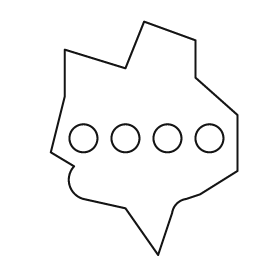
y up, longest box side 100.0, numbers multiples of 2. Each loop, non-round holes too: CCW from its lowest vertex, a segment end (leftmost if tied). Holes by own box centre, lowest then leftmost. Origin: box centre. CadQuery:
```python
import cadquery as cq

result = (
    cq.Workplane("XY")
    .moveTo(6.0, -50.0)
    .lineTo(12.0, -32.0)
    .threePointArc((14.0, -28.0), (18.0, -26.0))
    .lineTo(24.0, -24.0)
    .lineTo(40.0, -14.0)
    .lineTo(40.0, 10.0)
    .lineTo(22.0, 26.0)
    .lineTo(22.0, 42.0)
    .lineTo(0.0, 50.0)
    .lineTo(-8.0, 30.0)
    .lineTo(-34.0, 38.0)
    .lineTo(-34.0, 18.0)
    .lineTo(-40.0, -6.0)
    .lineTo(-30.0, -12.0)
    .threePointArc((-32.0, -20.0), (-26.0, -26.0))
    .lineTo(-8.0, -30.0)
    .close()
    .moveTo(-26.0, 0.0)
    .circle(6.0)
    .moveTo(-8.0, 0.0)
    .circle(6.0)
    .moveTo(10.0, 0.0)
    .circle(6.0)
    .moveTo(28.0, 0.0)
    .circle(6.0)
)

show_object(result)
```